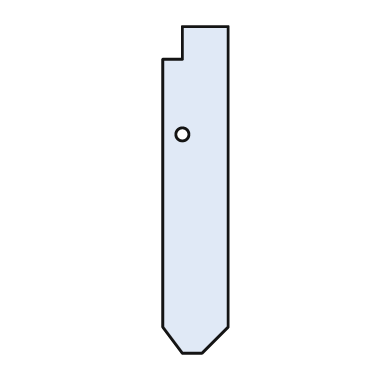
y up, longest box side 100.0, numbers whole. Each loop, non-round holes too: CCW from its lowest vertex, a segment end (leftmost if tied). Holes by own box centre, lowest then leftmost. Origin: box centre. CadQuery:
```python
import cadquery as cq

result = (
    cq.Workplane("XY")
    .moveTo(-4.0, -50.0)
    .lineTo(2.0, -50.0)
    .lineTo(10.0, -42.0)
    .lineTo(10.0, 50.0)
    .lineTo(-4.0, 50.0)
    .lineTo(-4.0, 40.0)
    .lineTo(-10.0, 40.0)
    .lineTo(-10.0, -42.0)
    .close()
    .moveTo(-4.0, 17.0)
    .circle(2.0)
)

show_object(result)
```